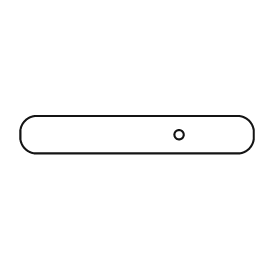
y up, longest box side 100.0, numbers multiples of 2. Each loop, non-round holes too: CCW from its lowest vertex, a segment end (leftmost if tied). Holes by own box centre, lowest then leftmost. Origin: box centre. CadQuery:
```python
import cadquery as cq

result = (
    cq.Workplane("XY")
    .moveTo(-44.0, -8.0)
    .lineTo(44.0, -8.0)
    .threePointArc((48.0, -6.0), (50.0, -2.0))
    .lineTo(50.0, 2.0)
    .threePointArc((48.0, 6.0), (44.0, 8.0))
    .lineTo(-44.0, 8.0)
    .threePointArc((-48.0, 6.0), (-50.0, 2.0))
    .lineTo(-50.0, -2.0)
    .threePointArc((-48.0, -6.0), (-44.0, -8.0))
    .close()
    .moveTo(18.0, 0.0)
    .circle(2.0)
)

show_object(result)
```